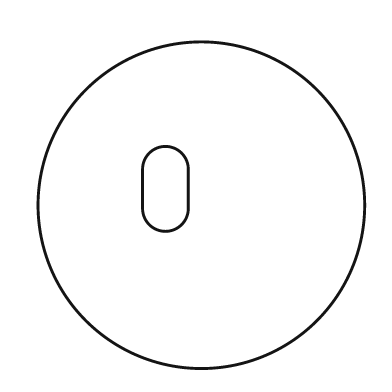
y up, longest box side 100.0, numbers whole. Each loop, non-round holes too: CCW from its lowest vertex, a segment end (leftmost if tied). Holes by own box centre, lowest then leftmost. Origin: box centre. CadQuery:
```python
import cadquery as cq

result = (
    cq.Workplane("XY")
    .moveTo(0.0, 0.0)
    .circle(50.0)
    .moveTo(-18.0, -1.0)
    .threePointArc((-11.0, -8.0), (-4.0, -1.0))
    .lineTo(-4.0, 11.0)
    .threePointArc((-11.0, 18.0), (-18.0, 11.0))
    .close()
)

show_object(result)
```